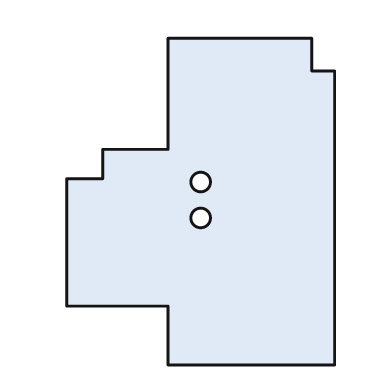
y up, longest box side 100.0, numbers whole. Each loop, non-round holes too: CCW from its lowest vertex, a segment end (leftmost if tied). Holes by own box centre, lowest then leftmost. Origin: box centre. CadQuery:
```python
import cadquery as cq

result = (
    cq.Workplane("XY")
    .moveTo(-10.0, -50.0)
    .lineTo(41.0, -50.0)
    .lineTo(41.0, 40.0)
    .lineTo(34.0, 40.0)
    .lineTo(34.0, 50.0)
    .lineTo(-10.0, 50.0)
    .lineTo(-10.0, 16.0)
    .lineTo(-30.0, 16.0)
    .lineTo(-30.0, 7.0)
    .lineTo(-41.0, 7.0)
    .lineTo(-41.0, -32.0)
    .lineTo(-10.0, -32.0)
    .close()
    .moveTo(0.0, -5.0)
    .circle(3.0)
    .moveTo(0.0, 6.0)
    .circle(3.0)
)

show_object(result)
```